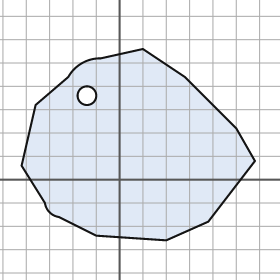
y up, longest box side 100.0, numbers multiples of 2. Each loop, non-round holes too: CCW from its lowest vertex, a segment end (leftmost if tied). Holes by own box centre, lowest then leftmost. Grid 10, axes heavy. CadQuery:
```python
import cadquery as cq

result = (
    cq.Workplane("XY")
    .moveTo(20.0, -26.0)
    .lineTo(38.0, -18.0)
    .lineTo(58.0, 8.0)
    .lineTo(50.0, 22.0)
    .lineTo(28.0, 44.0)
    .lineTo(10.0, 56.0)
    .lineTo(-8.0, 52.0)
    .threePointArc((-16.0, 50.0), (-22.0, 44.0))
    .lineTo(-36.0, 32.0)
    .lineTo(-42.0, 6.0)
    .lineTo(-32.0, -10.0)
    .threePointArc((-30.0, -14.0), (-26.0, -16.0))
    .lineTo(-10.0, -24.0)
    .close()
    .moveTo(-14.0, 36.0)
    .circle(4.0)
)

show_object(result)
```